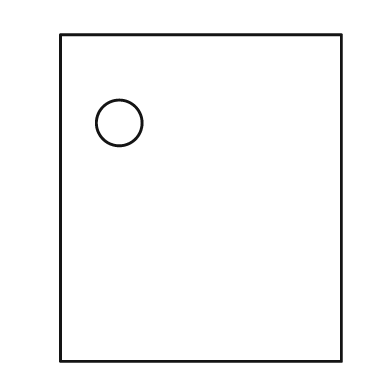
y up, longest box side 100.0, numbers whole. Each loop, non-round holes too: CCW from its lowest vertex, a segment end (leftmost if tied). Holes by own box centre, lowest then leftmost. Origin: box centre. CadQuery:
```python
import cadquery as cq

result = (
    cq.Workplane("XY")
    .moveTo(-43.0, -50.0)
    .lineTo(43.0, -50.0)
    .lineTo(43.0, 50.0)
    .lineTo(-43.0, 50.0)
    .close()
    .moveTo(-25.0, 23.0)
    .circle(7.0)
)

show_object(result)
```